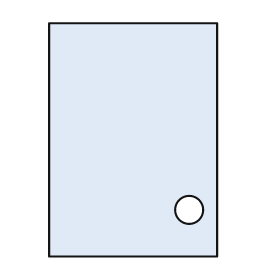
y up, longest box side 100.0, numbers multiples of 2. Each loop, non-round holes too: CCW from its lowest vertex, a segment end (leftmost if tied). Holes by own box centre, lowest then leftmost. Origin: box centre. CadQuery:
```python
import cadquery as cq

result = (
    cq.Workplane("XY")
    .moveTo(-36.0, -50.0)
    .lineTo(36.0, -50.0)
    .lineTo(36.0, 50.0)
    .lineTo(-36.0, 50.0)
    .close()
    .moveTo(24.0, -30.0)
    .circle(6.0)
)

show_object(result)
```